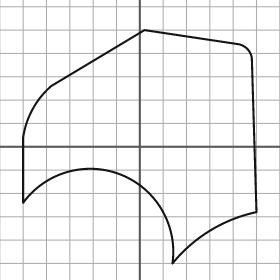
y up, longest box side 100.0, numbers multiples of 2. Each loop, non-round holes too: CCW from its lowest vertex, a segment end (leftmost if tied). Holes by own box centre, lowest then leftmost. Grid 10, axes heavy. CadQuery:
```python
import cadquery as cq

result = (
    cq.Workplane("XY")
    .moveTo(14.0, -50.0)
    .threePointArc((30.0, -36.0), (50.0, -28.0))
    .lineTo(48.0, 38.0)
    .threePointArc((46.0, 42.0), (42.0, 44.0))
    .lineTo(2.0, 50.0)
    .lineTo(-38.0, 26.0)
    .threePointArc((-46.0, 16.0), (-50.0, 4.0))
    .lineTo(-50.0, -24.0)
    .threePointArc((-8.0, -12.0), (14.0, -50.0))
    .close()
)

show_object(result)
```